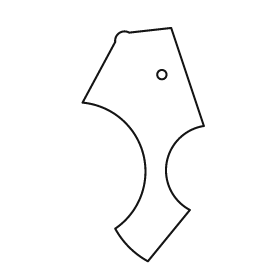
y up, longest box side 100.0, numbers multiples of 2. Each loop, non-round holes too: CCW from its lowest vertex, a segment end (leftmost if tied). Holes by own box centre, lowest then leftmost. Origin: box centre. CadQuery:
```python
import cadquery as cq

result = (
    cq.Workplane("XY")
    .moveTo(2.0, -50.0)
    .lineTo(20.0, -28.0)
    .threePointArc((10.0, -8.0), (26.0, 8.0))
    .lineTo(12.0, 50.0)
    .lineTo(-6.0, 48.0)
    .threePointArc((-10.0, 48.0), (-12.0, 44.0))
    .lineTo(-26.0, 18.0)
    .threePointArc((0.0, -4.0), (-12.0, -36.0))
    .threePointArc((-6.0, -44.0), (2.0, -50.0))
    .close()
    .moveTo(8.0, 30.0)
    .circle(2.0)
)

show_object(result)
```